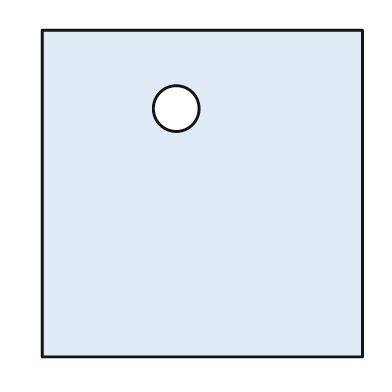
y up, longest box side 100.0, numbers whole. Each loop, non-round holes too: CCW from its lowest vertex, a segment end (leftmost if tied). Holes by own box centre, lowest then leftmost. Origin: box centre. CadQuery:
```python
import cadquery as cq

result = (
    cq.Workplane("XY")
    .moveTo(-49.0, -50.0)
    .lineTo(49.0, -50.0)
    .lineTo(49.0, 50.0)
    .lineTo(-49.0, 50.0)
    .close()
    .moveTo(-8.0, 26.0)
    .circle(7.0)
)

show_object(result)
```